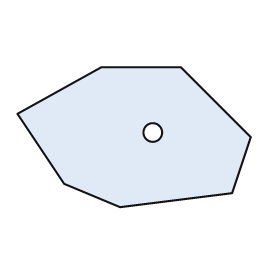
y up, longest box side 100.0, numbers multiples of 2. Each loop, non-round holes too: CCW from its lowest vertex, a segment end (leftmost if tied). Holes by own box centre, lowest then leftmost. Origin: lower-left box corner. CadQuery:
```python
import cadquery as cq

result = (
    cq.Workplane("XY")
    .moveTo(44.0, 0.0)
    .lineTo(92.0, 6.0)
    .lineTo(100.0, 30.0)
    .lineTo(70.0, 60.0)
    .lineTo(36.0, 60.0)
    .lineTo(0.0, 40.0)
    .lineTo(20.0, 10.0)
    .close()
    .moveTo(58.0, 32.0)
    .circle(4.0)
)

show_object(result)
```